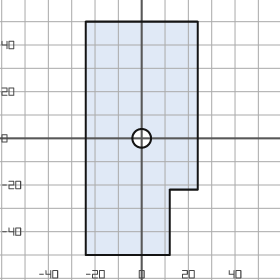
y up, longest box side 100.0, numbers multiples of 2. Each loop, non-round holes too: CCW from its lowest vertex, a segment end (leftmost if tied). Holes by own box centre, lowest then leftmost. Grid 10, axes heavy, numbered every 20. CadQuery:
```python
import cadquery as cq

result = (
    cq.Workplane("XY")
    .moveTo(-24.0, -50.0)
    .lineTo(12.0, -50.0)
    .lineTo(12.0, -22.0)
    .lineTo(24.0, -22.0)
    .lineTo(24.0, 50.0)
    .lineTo(-24.0, 50.0)
    .close()
    .moveTo(0.0, 0.0)
    .circle(4.0)
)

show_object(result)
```